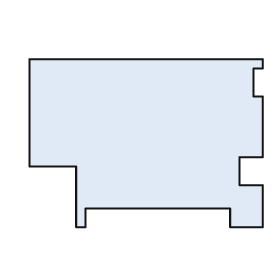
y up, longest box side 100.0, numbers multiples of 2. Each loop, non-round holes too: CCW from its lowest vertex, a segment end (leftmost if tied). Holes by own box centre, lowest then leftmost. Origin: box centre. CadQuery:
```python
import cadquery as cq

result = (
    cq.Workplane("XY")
    .moveTo(-30.0, -36.0)
    .lineTo(-26.0, -36.0)
    .lineTo(-26.0, -28.0)
    .lineTo(36.0, -28.0)
    .lineTo(36.0, -36.0)
    .lineTo(50.0, -36.0)
    .lineTo(50.0, -18.0)
    .lineTo(40.0, -18.0)
    .lineTo(40.0, -6.0)
    .lineTo(50.0, -6.0)
    .lineTo(50.0, 20.0)
    .lineTo(46.0, 20.0)
    .lineTo(46.0, 32.0)
    .lineTo(50.0, 32.0)
    .lineTo(50.0, 36.0)
    .lineTo(-50.0, 36.0)
    .lineTo(-50.0, -10.0)
    .lineTo(-30.0, -10.0)
    .close()
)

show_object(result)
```